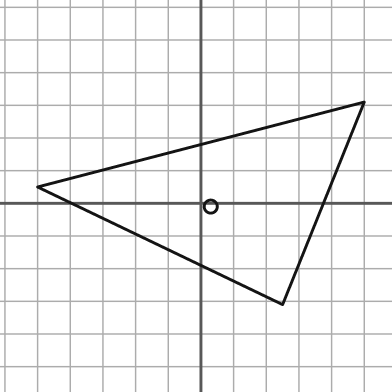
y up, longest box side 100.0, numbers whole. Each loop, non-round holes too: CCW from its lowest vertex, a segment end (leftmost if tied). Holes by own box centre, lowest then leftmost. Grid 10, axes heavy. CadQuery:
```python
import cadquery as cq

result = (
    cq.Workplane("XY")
    .moveTo(25.0, -31.0)
    .lineTo(50.0, 31.0)
    .lineTo(-50.0, 5.0)
    .close()
    .moveTo(3.0, -1.0)
    .circle(2.0)
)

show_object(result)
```